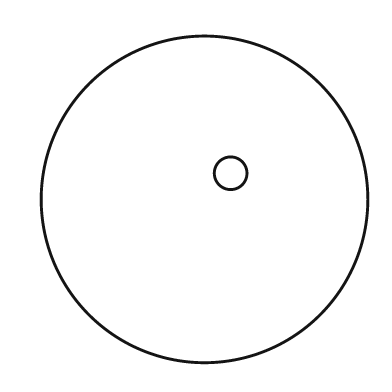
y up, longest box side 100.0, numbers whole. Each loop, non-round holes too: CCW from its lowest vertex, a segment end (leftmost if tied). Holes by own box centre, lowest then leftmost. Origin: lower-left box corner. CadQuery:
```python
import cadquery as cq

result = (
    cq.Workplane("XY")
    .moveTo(50.0, 50.0)
    .circle(50.0)
    .moveTo(58.0, 58.0)
    .circle(5.0)
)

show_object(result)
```